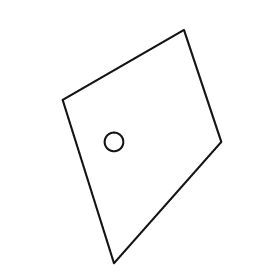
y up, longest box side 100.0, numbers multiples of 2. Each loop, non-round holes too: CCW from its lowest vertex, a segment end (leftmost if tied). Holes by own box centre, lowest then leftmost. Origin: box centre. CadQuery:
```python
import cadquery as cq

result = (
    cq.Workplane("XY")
    .moveTo(-12.0, -50.0)
    .lineTo(34.0, 2.0)
    .lineTo(18.0, 50.0)
    .lineTo(-34.0, 20.0)
    .close()
    .moveTo(-12.0, 2.0)
    .circle(4.0)
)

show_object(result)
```